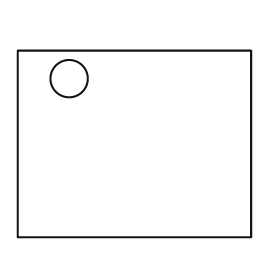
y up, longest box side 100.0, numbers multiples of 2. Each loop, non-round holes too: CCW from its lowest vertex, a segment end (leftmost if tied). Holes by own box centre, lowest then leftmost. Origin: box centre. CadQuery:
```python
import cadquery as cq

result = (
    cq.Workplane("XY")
    .moveTo(-50.0, -40.0)
    .lineTo(50.0, -40.0)
    .lineTo(50.0, 40.0)
    .lineTo(-50.0, 40.0)
    .close()
    .moveTo(-28.0, 28.0)
    .circle(8.0)
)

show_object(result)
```